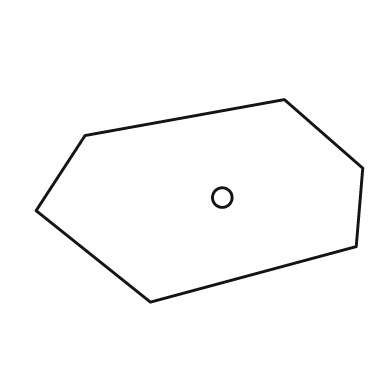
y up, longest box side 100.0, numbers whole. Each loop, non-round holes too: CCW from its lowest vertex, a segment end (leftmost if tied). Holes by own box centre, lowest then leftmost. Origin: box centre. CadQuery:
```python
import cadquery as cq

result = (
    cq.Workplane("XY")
    .moveTo(-15.0, -31.0)
    .lineTo(48.0, -14.0)
    .lineTo(50.0, 10.0)
    .lineTo(26.0, 31.0)
    .lineTo(-35.0, 20.0)
    .lineTo(-50.0, -3.0)
    .close()
    .moveTo(7.0, 1.0)
    .circle(3.0)
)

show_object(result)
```